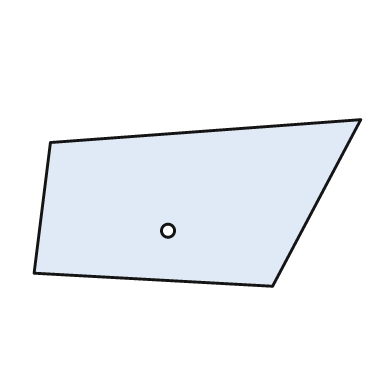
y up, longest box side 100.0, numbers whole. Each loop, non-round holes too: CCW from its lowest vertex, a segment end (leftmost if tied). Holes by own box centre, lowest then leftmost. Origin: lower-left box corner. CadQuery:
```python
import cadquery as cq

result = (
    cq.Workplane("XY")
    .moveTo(73.0, 0.0)
    .lineTo(100.0, 51.0)
    .lineTo(5.0, 44.0)
    .lineTo(0.0, 4.0)
    .close()
    .moveTo(41.0, 17.0)
    .circle(2.0)
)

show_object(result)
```